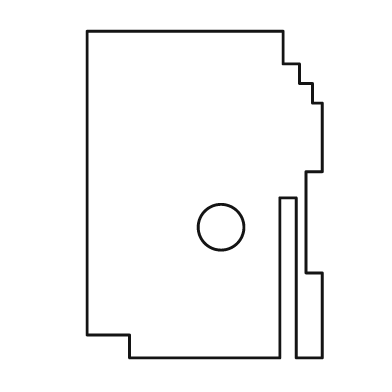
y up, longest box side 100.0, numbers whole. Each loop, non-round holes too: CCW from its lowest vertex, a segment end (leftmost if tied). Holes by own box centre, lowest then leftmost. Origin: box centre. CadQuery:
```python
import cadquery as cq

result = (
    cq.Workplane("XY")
    .moveTo(-23.0, -50.0)
    .lineTo(23.0, -50.0)
    .lineTo(23.0, -1.0)
    .lineTo(28.0, -1.0)
    .lineTo(28.0, -50.0)
    .lineTo(36.0, -50.0)
    .lineTo(36.0, -24.0)
    .lineTo(31.0, -24.0)
    .lineTo(31.0, 7.0)
    .lineTo(36.0, 7.0)
    .lineTo(36.0, 28.0)
    .lineTo(33.0, 28.0)
    .lineTo(33.0, 34.0)
    .lineTo(29.0, 34.0)
    .lineTo(29.0, 40.0)
    .lineTo(24.0, 40.0)
    .lineTo(24.0, 50.0)
    .lineTo(-36.0, 50.0)
    .lineTo(-36.0, -43.0)
    .lineTo(-23.0, -43.0)
    .close()
    .moveTo(5.0, -10.0)
    .circle(7.0)
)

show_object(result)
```